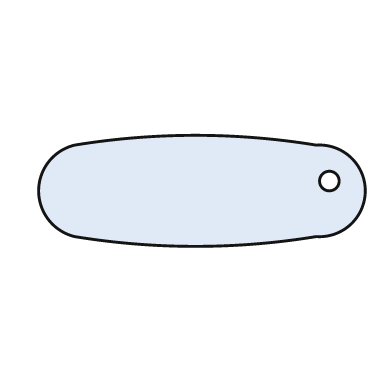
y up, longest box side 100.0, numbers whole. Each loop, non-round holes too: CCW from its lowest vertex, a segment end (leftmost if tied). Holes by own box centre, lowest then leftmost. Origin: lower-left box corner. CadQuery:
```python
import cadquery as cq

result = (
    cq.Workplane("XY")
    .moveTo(11.0, 3.0)
    .threePointArc((48.0, 0.0), (85.0, 3.0))
    .threePointArc((100.0, 17.0), (85.0, 31.0))
    .threePointArc((48.0, 34.0), (11.0, 31.0))
    .threePointArc((0.0, 17.0), (11.0, 3.0))
    .close()
    .moveTo(89.0, 20.0)
    .circle(3.0)
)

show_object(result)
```